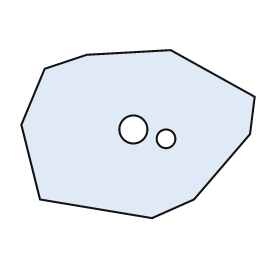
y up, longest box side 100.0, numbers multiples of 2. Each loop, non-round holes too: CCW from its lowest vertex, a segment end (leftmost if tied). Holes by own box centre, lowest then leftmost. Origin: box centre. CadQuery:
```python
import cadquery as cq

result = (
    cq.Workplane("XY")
    .moveTo(6.0, -36.0)
    .lineTo(24.0, -28.0)
    .lineTo(48.0, 0.0)
    .lineTo(50.0, 16.0)
    .lineTo(14.0, 36.0)
    .lineTo(-22.0, 34.0)
    .lineTo(-40.0, 28.0)
    .lineTo(-50.0, 4.0)
    .lineTo(-42.0, -28.0)
    .close()
    .moveTo(12.0, -2.0)
    .circle(4.0)
    .moveTo(-2.0, 2.0)
    .circle(6.0)
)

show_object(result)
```